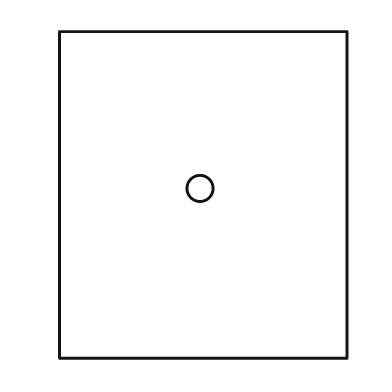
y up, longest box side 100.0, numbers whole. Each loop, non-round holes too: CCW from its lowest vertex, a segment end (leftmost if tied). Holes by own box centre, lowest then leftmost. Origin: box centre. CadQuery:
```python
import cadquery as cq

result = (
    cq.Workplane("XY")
    .moveTo(-44.0, -50.0)
    .lineTo(44.0, -50.0)
    .lineTo(44.0, 50.0)
    .lineTo(-44.0, 50.0)
    .close()
    .moveTo(-1.0, 2.0)
    .circle(4.0)
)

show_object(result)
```